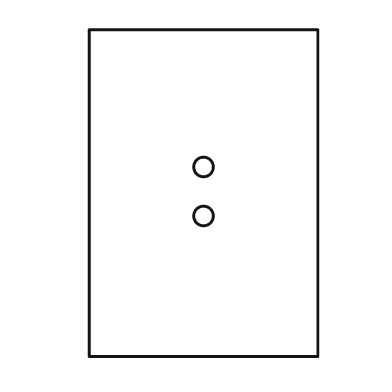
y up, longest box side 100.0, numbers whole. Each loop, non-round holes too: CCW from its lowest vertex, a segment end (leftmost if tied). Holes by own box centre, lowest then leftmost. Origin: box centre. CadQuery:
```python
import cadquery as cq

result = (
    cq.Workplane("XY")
    .moveTo(-35.0, -50.0)
    .lineTo(35.0, -50.0)
    .lineTo(35.0, 50.0)
    .lineTo(-35.0, 50.0)
    .close()
    .moveTo(0.0, -7.0)
    .circle(3.0)
    .moveTo(0.0, 8.0)
    .circle(3.0)
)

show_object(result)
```